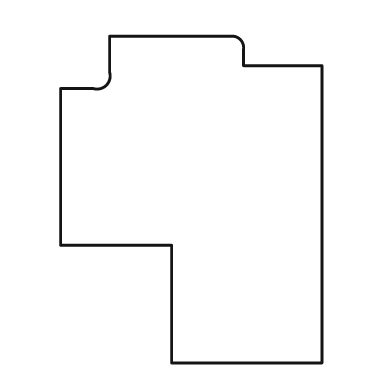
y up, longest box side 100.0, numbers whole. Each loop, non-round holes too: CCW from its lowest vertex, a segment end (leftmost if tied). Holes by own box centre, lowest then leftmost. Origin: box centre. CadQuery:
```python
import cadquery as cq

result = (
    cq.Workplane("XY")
    .moveTo(-6.0, -50.0)
    .lineTo(40.0, -50.0)
    .lineTo(40.0, 41.0)
    .lineTo(16.0, 41.0)
    .lineTo(16.0, 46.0)
    .threePointArc((15.0, 49.0), (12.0, 50.0))
    .lineTo(-25.0, 50.0)
    .lineTo(-25.0, 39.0)
    .threePointArc((-26.0, 35.0), (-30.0, 34.0))
    .lineTo(-40.0, 34.0)
    .lineTo(-40.0, -14.0)
    .lineTo(-6.0, -14.0)
    .close()
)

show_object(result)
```